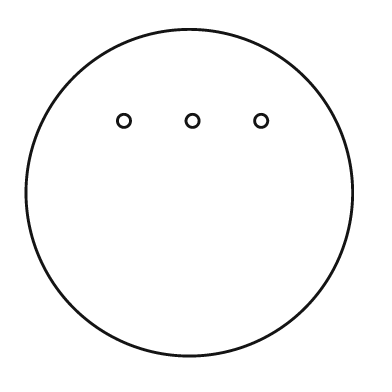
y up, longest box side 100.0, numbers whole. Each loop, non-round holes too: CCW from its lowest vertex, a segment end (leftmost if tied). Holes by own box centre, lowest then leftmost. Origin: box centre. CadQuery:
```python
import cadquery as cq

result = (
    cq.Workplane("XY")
    .moveTo(0.0, 0.0)
    .circle(50.0)
    .moveTo(-20.0, 22.0)
    .circle(2.0)
    .moveTo(1.0, 22.0)
    .circle(2.0)
    .moveTo(22.0, 22.0)
    .circle(2.0)
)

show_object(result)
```